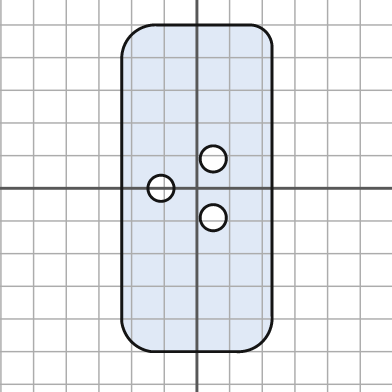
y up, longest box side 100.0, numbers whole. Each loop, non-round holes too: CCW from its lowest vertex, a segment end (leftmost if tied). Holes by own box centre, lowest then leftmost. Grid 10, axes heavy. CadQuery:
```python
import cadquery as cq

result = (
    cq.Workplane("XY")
    .moveTo(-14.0, -50.0)
    .lineTo(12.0, -50.0)
    .threePointArc((20.0, -47.0), (23.0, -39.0))
    .lineTo(23.0, 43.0)
    .threePointArc((21.0, 48.0), (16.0, 50.0))
    .lineTo(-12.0, 50.0)
    .threePointArc((-20.0, 47.0), (-23.0, 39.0))
    .lineTo(-23.0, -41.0)
    .threePointArc((-20.0, -47.0), (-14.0, -50.0))
    .close()
    .moveTo(5.0, -9.0)
    .circle(4.0)
    .moveTo(-11.0, 0.0)
    .circle(4.0)
    .moveTo(5.0, 9.0)
    .circle(4.0)
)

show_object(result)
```